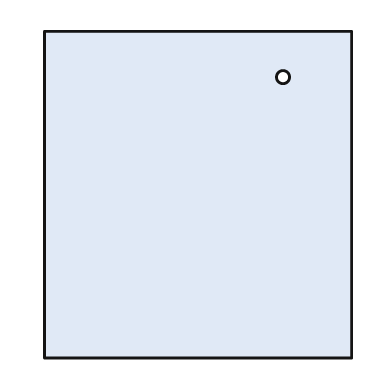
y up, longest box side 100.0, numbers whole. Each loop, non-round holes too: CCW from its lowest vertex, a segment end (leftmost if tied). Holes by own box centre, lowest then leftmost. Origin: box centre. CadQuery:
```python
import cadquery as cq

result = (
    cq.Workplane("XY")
    .moveTo(-47.0, -50.0)
    .lineTo(47.0, -50.0)
    .lineTo(47.0, 50.0)
    .lineTo(-47.0, 50.0)
    .close()
    .moveTo(26.0, 36.0)
    .circle(2.0)
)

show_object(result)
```